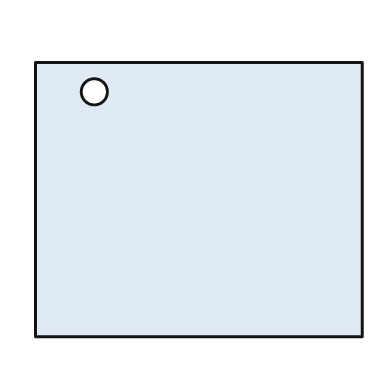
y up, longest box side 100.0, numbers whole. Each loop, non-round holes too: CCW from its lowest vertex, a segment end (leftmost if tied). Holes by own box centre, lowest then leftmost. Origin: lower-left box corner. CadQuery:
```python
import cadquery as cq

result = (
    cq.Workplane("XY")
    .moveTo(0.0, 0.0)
    .lineTo(100.0, 0.0)
    .lineTo(100.0, 84.0)
    .lineTo(0.0, 84.0)
    .close()
    .moveTo(18.0, 75.0)
    .circle(4.0)
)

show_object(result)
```